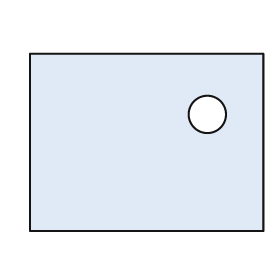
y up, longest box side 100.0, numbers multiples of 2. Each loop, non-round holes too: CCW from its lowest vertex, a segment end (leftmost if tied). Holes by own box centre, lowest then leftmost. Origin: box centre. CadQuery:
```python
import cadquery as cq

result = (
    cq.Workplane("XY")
    .moveTo(-50.0, -38.0)
    .lineTo(50.0, -38.0)
    .lineTo(50.0, 38.0)
    .lineTo(-50.0, 38.0)
    .close()
    .moveTo(26.0, 12.0)
    .circle(8.0)
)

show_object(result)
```